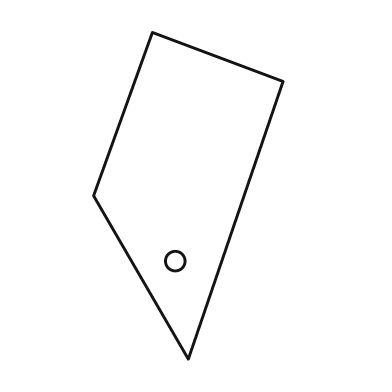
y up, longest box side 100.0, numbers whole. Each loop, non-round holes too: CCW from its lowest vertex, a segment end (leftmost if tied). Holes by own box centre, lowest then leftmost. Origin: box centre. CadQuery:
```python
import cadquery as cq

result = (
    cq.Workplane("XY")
    .moveTo(0.0, -50.0)
    .lineTo(29.0, 35.0)
    .lineTo(-11.0, 50.0)
    .lineTo(-29.0, 0.0)
    .close()
    .moveTo(-4.0, -20.0)
    .circle(3.0)
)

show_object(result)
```